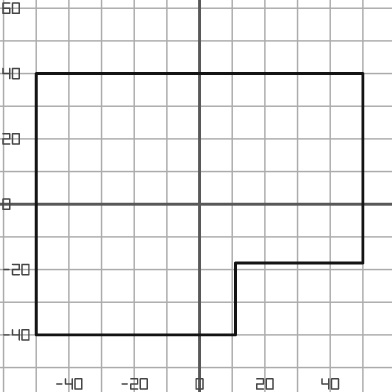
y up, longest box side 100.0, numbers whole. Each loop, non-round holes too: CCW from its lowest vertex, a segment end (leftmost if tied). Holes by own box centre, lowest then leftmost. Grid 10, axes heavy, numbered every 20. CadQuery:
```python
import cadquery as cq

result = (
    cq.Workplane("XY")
    .moveTo(-50.0, -40.0)
    .lineTo(11.0, -40.0)
    .lineTo(11.0, -18.0)
    .lineTo(50.0, -18.0)
    .lineTo(50.0, 40.0)
    .lineTo(-50.0, 40.0)
    .close()
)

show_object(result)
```